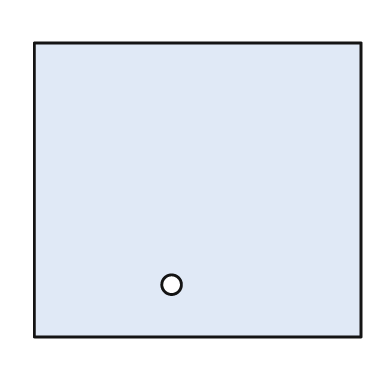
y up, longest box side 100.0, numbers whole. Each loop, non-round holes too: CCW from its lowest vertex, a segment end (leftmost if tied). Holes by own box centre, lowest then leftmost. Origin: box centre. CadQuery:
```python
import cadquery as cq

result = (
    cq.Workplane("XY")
    .moveTo(-50.0, -45.0)
    .lineTo(50.0, -45.0)
    .lineTo(50.0, 45.0)
    .lineTo(-50.0, 45.0)
    .close()
    .moveTo(-8.0, -29.0)
    .circle(3.0)
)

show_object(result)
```